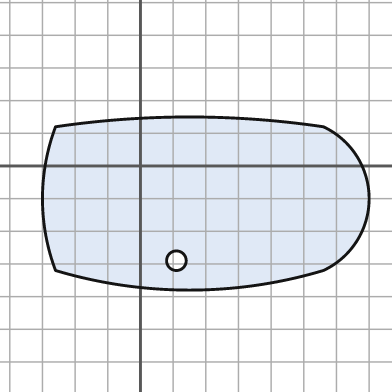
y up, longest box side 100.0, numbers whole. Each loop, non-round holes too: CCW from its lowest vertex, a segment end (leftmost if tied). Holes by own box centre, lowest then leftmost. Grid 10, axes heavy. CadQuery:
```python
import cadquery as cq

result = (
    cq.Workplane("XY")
    .moveTo(-26.0, -32.0)
    .threePointArc((15.0, -38.0), (56.0, -32.0))
    .threePointArc((70.0, -10.0), (56.0, 12.0))
    .threePointArc((15.0, 15.0), (-26.0, 12.0))
    .threePointArc((-30.0, -10.0), (-26.0, -32.0))
    .close()
    .moveTo(11.0, -29.0)
    .circle(3.0)
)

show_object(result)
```